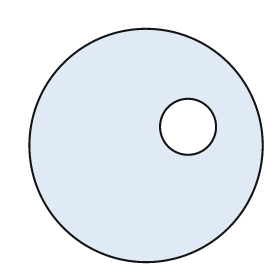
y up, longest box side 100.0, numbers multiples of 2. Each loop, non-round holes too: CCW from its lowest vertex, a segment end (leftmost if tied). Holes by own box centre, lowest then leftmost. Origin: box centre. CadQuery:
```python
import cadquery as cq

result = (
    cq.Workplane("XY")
    .moveTo(0.0, 0.0)
    .circle(50.0)
    .moveTo(18.0, 8.0)
    .circle(12.0)
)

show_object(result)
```